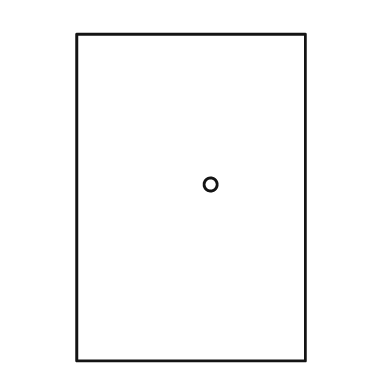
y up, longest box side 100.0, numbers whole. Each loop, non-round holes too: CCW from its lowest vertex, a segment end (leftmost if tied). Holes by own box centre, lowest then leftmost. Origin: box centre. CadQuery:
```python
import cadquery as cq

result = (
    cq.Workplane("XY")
    .moveTo(-35.0, -50.0)
    .lineTo(35.0, -50.0)
    .lineTo(35.0, 50.0)
    .lineTo(-35.0, 50.0)
    .close()
    .moveTo(6.0, 4.0)
    .circle(2.0)
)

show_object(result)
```